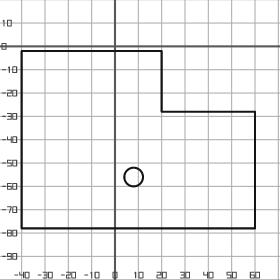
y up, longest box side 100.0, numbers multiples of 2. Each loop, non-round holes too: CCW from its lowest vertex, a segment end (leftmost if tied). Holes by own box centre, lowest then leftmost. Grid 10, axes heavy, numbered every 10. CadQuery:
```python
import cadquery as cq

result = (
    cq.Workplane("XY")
    .moveTo(-40.0, -78.0)
    .lineTo(60.0, -78.0)
    .lineTo(60.0, -28.0)
    .lineTo(20.0, -28.0)
    .lineTo(20.0, -2.0)
    .lineTo(-40.0, -2.0)
    .close()
    .moveTo(8.0, -56.0)
    .circle(4.0)
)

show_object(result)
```